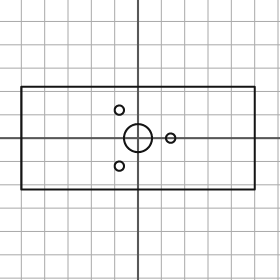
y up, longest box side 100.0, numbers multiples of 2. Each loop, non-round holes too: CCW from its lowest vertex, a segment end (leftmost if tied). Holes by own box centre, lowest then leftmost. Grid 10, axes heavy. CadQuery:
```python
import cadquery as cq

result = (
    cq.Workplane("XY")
    .moveTo(-50.0, -22.0)
    .lineTo(50.0, -22.0)
    .lineTo(50.0, 22.0)
    .lineTo(-50.0, 22.0)
    .close()
    .moveTo(-8.0, -12.0)
    .circle(2.0)
    .moveTo(0.0, 0.0)
    .circle(6.0)
    .moveTo(14.0, 0.0)
    .circle(2.0)
    .moveTo(-8.0, 12.0)
    .circle(2.0)
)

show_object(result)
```